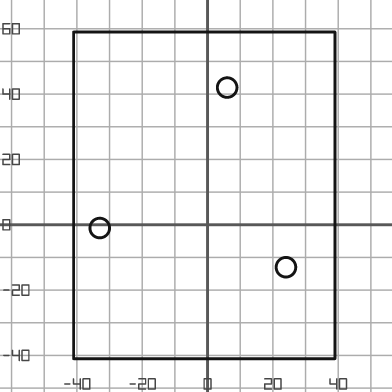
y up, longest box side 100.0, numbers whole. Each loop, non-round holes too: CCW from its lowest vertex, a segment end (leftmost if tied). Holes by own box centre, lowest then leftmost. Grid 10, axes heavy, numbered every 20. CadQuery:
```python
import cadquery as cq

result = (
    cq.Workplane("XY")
    .moveTo(-41.0, -41.0)
    .lineTo(39.0, -41.0)
    .lineTo(39.0, 59.0)
    .lineTo(-41.0, 59.0)
    .close()
    .moveTo(24.0, -13.0)
    .circle(3.0)
    .moveTo(-33.0, -1.0)
    .circle(3.0)
    .moveTo(6.0, 42.0)
    .circle(3.0)
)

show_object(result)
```